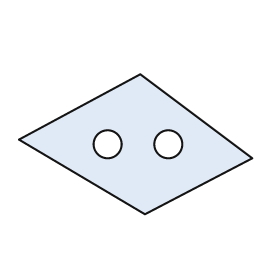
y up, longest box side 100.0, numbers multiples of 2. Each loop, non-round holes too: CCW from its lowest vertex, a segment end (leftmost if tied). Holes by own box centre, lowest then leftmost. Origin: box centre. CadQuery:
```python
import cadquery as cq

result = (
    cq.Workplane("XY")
    .moveTo(4.0, -30.0)
    .lineTo(50.0, -6.0)
    .lineTo(2.0, 30.0)
    .lineTo(-50.0, 2.0)
    .close()
    .moveTo(-12.0, 0.0)
    .circle(6.0)
    .moveTo(14.0, 0.0)
    .circle(6.0)
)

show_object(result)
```